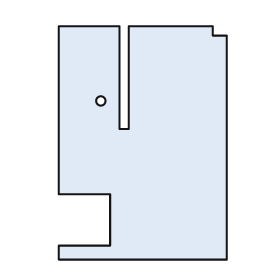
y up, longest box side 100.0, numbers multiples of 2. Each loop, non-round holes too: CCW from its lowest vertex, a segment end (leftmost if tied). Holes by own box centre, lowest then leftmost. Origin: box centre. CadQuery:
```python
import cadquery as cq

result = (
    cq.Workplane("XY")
    .moveTo(-36.0, -50.0)
    .lineTo(36.0, -50.0)
    .lineTo(36.0, 46.0)
    .lineTo(30.0, 46.0)
    .lineTo(30.0, 50.0)
    .lineTo(-6.0, 50.0)
    .lineTo(-6.0, 6.0)
    .lineTo(-10.0, 6.0)
    .lineTo(-10.0, 50.0)
    .lineTo(-36.0, 50.0)
    .lineTo(-36.0, -22.0)
    .lineTo(-14.0, -22.0)
    .lineTo(-14.0, -44.0)
    .lineTo(-36.0, -44.0)
    .close()
    .moveTo(-18.0, 18.0)
    .circle(2.0)
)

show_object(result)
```